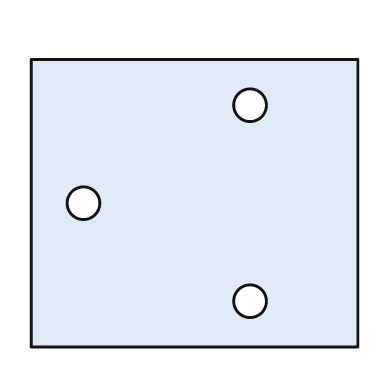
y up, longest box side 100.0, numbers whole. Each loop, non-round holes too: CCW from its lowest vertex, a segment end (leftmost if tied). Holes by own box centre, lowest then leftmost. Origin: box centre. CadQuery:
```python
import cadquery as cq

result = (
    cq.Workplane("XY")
    .moveTo(-50.0, -44.0)
    .lineTo(50.0, -44.0)
    .lineTo(50.0, 44.0)
    .lineTo(-50.0, 44.0)
    .close()
    .moveTo(17.0, -30.0)
    .circle(5.0)
    .moveTo(-34.0, 0.0)
    .circle(5.0)
    .moveTo(17.0, 30.0)
    .circle(5.0)
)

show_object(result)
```